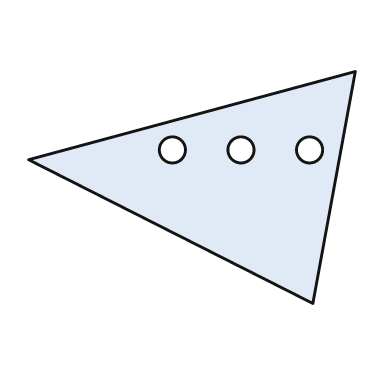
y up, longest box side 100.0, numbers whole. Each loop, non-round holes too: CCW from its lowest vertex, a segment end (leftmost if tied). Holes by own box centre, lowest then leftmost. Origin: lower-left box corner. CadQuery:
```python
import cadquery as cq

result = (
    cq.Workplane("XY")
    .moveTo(87.0, 0.0)
    .lineTo(100.0, 71.0)
    .lineTo(0.0, 44.0)
    .close()
    .moveTo(44.0, 47.0)
    .circle(4.0)
    .moveTo(65.0, 47.0)
    .circle(4.0)
    .moveTo(86.0, 47.0)
    .circle(4.0)
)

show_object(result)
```